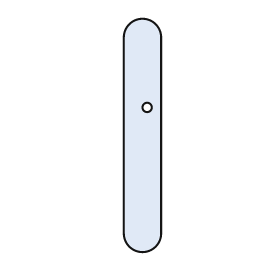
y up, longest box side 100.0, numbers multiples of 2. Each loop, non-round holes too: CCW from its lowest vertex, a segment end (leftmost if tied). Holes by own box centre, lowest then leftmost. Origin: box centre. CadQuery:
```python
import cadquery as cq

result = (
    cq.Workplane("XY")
    .moveTo(-8.0, -42.0)
    .threePointArc((0.0, -50.0), (8.0, -42.0))
    .lineTo(8.0, 42.0)
    .threePointArc((0.0, 50.0), (-8.0, 42.0))
    .close()
    .moveTo(2.0, 12.0)
    .circle(2.0)
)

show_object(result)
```